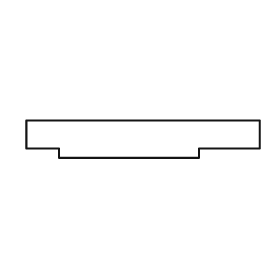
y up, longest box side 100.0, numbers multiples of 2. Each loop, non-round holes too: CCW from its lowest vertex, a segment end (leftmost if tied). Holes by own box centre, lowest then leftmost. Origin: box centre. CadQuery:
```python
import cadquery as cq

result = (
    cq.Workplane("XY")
    .moveTo(-36.0, -8.0)
    .lineTo(24.0, -8.0)
    .lineTo(24.0, -4.0)
    .lineTo(50.0, -4.0)
    .lineTo(50.0, 8.0)
    .lineTo(-50.0, 8.0)
    .lineTo(-50.0, -4.0)
    .lineTo(-36.0, -4.0)
    .close()
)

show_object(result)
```